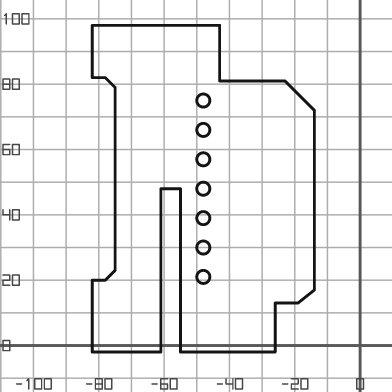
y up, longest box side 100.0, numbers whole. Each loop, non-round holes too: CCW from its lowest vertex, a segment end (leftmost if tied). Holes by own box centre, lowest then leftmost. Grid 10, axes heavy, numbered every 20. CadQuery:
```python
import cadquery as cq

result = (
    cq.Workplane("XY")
    .moveTo(-82.0, -2.0)
    .lineTo(-61.0, -2.0)
    .lineTo(-61.0, 48.0)
    .lineTo(-55.0, 48.0)
    .lineTo(-55.0, -2.0)
    .lineTo(-26.0, -2.0)
    .lineTo(-26.0, 13.0)
    .lineTo(-19.0, 13.0)
    .lineTo(-14.0, 17.0)
    .lineTo(-14.0, 72.0)
    .lineTo(-23.0, 81.0)
    .lineTo(-43.0, 81.0)
    .lineTo(-43.0, 98.0)
    .lineTo(-82.0, 98.0)
    .lineTo(-82.0, 82.0)
    .lineTo(-78.0, 82.0)
    .lineTo(-75.0, 79.0)
    .lineTo(-75.0, 23.0)
    .lineTo(-78.0, 20.0)
    .lineTo(-82.0, 20.0)
    .close()
    .moveTo(-48.0, 21.0)
    .circle(2.0)
    .moveTo(-48.0, 30.0)
    .circle(2.0)
    .moveTo(-48.0, 39.0)
    .circle(2.0)
    .moveTo(-48.0, 48.0)
    .circle(2.0)
    .moveTo(-48.0, 57.0)
    .circle(2.0)
    .moveTo(-48.0, 66.0)
    .circle(2.0)
    .moveTo(-48.0, 75.0)
    .circle(2.0)
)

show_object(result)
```